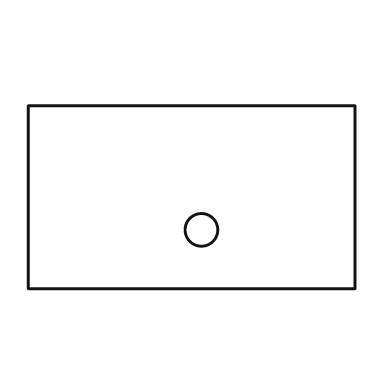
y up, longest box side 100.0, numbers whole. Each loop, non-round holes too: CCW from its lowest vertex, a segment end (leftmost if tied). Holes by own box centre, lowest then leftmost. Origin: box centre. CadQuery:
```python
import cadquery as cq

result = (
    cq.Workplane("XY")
    .moveTo(-50.0, -28.0)
    .lineTo(50.0, -28.0)
    .lineTo(50.0, 28.0)
    .lineTo(-50.0, 28.0)
    .close()
    .moveTo(3.0, -10.0)
    .circle(5.0)
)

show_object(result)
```